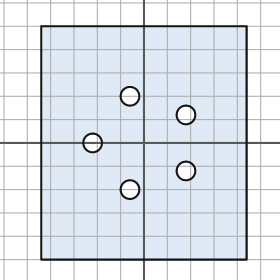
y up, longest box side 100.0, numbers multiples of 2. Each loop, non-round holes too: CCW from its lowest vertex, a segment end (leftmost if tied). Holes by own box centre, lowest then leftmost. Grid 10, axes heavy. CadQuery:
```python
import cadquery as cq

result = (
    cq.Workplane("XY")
    .moveTo(-44.0, -50.0)
    .lineTo(44.0, -50.0)
    .lineTo(44.0, 50.0)
    .lineTo(-44.0, 50.0)
    .close()
    .moveTo(-6.0, -20.0)
    .circle(4.0)
    .moveTo(18.0, -12.0)
    .circle(4.0)
    .moveTo(-22.0, 0.0)
    .circle(4.0)
    .moveTo(18.0, 12.0)
    .circle(4.0)
    .moveTo(-6.0, 20.0)
    .circle(4.0)
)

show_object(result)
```